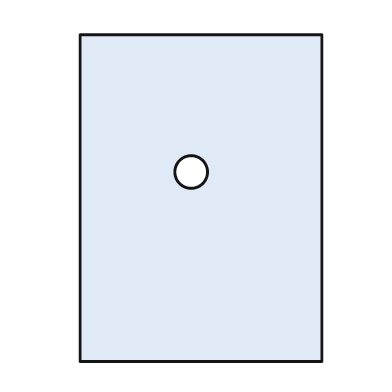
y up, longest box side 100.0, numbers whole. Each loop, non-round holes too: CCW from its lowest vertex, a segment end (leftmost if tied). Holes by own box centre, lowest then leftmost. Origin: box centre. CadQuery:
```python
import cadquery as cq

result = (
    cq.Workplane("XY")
    .moveTo(-37.0, -50.0)
    .lineTo(37.0, -50.0)
    .lineTo(37.0, 50.0)
    .lineTo(-37.0, 50.0)
    .close()
    .moveTo(-3.0, 8.0)
    .circle(5.0)
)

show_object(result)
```